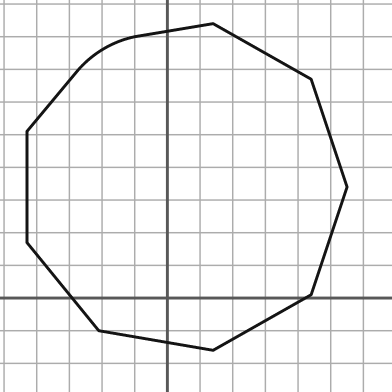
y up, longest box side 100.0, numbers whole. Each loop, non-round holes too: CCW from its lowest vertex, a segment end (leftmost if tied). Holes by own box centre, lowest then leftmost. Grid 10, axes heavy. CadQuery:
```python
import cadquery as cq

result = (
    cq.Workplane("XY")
    .moveTo(14.0, -16.0)
    .lineTo(44.0, 1.0)
    .lineTo(55.0, 34.0)
    .lineTo(44.0, 67.0)
    .lineTo(14.0, 84.0)
    .lineTo(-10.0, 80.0)
    .threePointArc((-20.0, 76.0), (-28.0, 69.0))
    .lineTo(-43.0, 51.0)
    .lineTo(-43.0, 17.0)
    .lineTo(-21.0, -10.0)
    .close()
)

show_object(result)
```